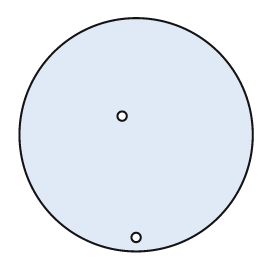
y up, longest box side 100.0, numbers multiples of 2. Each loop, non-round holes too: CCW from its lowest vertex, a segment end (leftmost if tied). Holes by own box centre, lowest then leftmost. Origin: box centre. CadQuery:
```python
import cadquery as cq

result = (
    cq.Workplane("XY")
    .moveTo(0.0, 0.0)
    .circle(50.0)
    .moveTo(0.0, -44.0)
    .circle(2.0)
    .moveTo(-6.0, 8.0)
    .circle(2.0)
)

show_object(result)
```